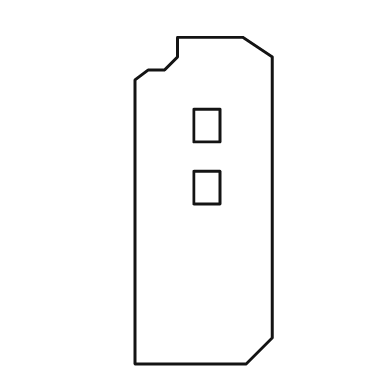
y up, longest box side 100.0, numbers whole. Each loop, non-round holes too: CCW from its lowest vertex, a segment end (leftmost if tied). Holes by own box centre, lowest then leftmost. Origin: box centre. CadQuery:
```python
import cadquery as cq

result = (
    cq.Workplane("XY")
    .moveTo(-21.0, -50.0)
    .lineTo(13.0, -50.0)
    .lineTo(21.0, -42.0)
    .lineTo(21.0, 44.0)
    .lineTo(12.0, 50.0)
    .lineTo(-8.0, 50.0)
    .lineTo(-8.0, 44.0)
    .lineTo(-12.0, 40.0)
    .lineTo(-17.0, 40.0)
    .lineTo(-21.0, 37.0)
    .close()
    .moveTo(-3.0, -1.0)
    .lineTo(5.0, -1.0)
    .lineTo(5.0, 9.0)
    .lineTo(-3.0, 9.0)
    .close()
    .moveTo(-3.0, 18.0)
    .lineTo(5.0, 18.0)
    .lineTo(5.0, 28.0)
    .lineTo(-3.0, 28.0)
    .close()
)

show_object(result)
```